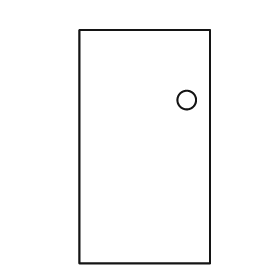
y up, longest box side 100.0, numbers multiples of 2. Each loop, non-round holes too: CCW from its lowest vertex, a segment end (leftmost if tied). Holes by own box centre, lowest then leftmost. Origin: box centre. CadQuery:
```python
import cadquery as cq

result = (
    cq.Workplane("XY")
    .moveTo(-28.0, -50.0)
    .lineTo(28.0, -50.0)
    .lineTo(28.0, 50.0)
    .lineTo(-28.0, 50.0)
    .close()
    .moveTo(18.0, 20.0)
    .circle(4.0)
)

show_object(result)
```